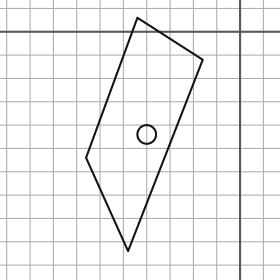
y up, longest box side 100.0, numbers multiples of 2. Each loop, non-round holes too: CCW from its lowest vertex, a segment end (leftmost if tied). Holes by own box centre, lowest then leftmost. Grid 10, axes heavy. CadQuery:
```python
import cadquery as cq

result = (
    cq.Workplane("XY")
    .moveTo(-48.0, -94.0)
    .lineTo(-16.0, -12.0)
    .lineTo(-44.0, 6.0)
    .lineTo(-66.0, -54.0)
    .close()
    .moveTo(-40.0, -44.0)
    .circle(4.0)
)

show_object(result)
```